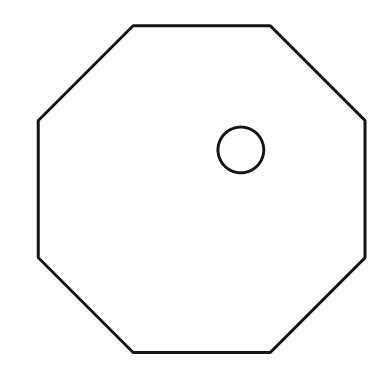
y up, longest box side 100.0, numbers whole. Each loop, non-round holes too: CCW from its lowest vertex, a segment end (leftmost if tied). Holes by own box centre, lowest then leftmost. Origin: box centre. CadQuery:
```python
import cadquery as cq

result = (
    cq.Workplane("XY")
    .moveTo(-21.0, -50.0)
    .lineTo(21.0, -50.0)
    .lineTo(50.0, -21.0)
    .lineTo(50.0, 21.0)
    .lineTo(21.0, 50.0)
    .lineTo(-21.0, 50.0)
    .lineTo(-50.0, 21.0)
    .lineTo(-50.0, -21.0)
    .close()
    .moveTo(12.0, 12.0)
    .circle(7.0)
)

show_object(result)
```